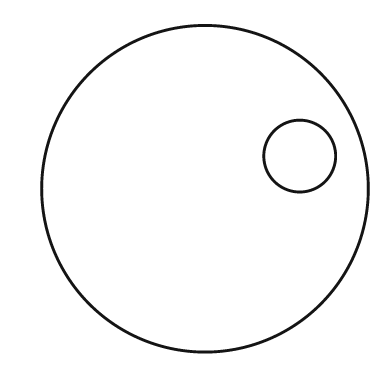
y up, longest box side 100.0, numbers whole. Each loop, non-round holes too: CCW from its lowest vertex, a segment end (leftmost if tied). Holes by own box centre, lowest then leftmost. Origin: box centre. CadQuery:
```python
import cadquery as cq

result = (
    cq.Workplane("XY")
    .moveTo(0.0, 0.0)
    .circle(50.0)
    .moveTo(29.0, 10.0)
    .circle(11.0)
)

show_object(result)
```